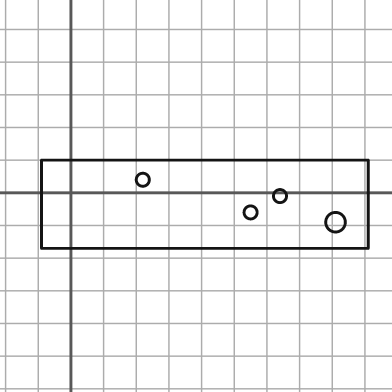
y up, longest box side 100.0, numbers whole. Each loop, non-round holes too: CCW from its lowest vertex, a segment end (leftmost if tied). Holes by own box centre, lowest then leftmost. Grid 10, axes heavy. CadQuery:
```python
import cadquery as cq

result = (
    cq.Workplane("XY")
    .moveTo(-9.0, -17.0)
    .lineTo(91.0, -17.0)
    .lineTo(91.0, 10.0)
    .lineTo(-9.0, 10.0)
    .close()
    .moveTo(81.0, -9.0)
    .circle(3.0)
    .moveTo(55.0, -6.0)
    .circle(2.0)
    .moveTo(64.0, -1.0)
    .circle(2.0)
    .moveTo(22.0, 4.0)
    .circle(2.0)
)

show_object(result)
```